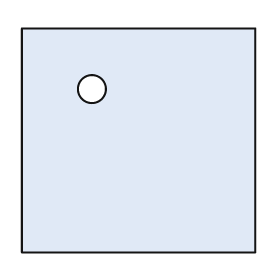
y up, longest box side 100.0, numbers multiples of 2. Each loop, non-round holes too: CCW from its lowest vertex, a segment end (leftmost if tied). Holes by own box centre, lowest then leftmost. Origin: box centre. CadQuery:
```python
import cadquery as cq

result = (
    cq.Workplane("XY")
    .moveTo(-50.0, -48.0)
    .lineTo(50.0, -48.0)
    .lineTo(50.0, 48.0)
    .lineTo(-50.0, 48.0)
    .close()
    .moveTo(-20.0, 22.0)
    .circle(6.0)
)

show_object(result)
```